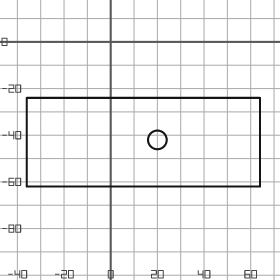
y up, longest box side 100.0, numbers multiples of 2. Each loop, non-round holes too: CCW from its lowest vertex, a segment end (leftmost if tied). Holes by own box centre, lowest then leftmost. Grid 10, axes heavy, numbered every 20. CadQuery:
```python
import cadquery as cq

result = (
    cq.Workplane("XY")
    .moveTo(-36.0, -62.0)
    .lineTo(64.0, -62.0)
    .lineTo(64.0, -24.0)
    .lineTo(-36.0, -24.0)
    .close()
    .moveTo(20.0, -42.0)
    .circle(4.0)
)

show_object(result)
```